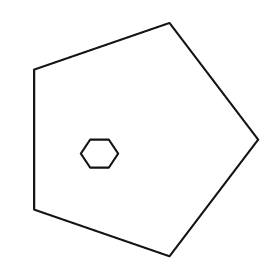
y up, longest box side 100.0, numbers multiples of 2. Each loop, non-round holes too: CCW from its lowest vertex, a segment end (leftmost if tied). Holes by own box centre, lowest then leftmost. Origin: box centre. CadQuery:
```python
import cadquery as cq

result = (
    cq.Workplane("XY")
    .moveTo(10.0, -50.0)
    .lineTo(48.0, 0.0)
    .lineTo(10.0, 50.0)
    .lineTo(-48.0, 30.0)
    .lineTo(-48.0, -30.0)
    .close()
    .moveTo(-24.0, -12.0)
    .lineTo(-16.0, -12.0)
    .lineTo(-12.0, -6.0)
    .lineTo(-16.0, 0.0)
    .lineTo(-24.0, 0.0)
    .lineTo(-28.0, -6.0)
    .close()
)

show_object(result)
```